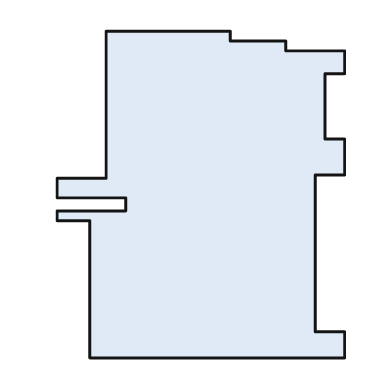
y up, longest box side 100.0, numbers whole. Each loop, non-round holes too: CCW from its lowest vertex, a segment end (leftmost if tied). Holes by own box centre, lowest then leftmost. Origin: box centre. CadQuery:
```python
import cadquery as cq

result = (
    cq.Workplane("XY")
    .moveTo(-34.0, -50.0)
    .lineTo(44.0, -50.0)
    .lineTo(44.0, -42.0)
    .lineTo(35.0, -42.0)
    .lineTo(35.0, 6.0)
    .lineTo(44.0, 6.0)
    .lineTo(44.0, 17.0)
    .lineTo(38.0, 17.0)
    .lineTo(38.0, 37.0)
    .lineTo(44.0, 37.0)
    .lineTo(44.0, 44.0)
    .lineTo(26.0, 44.0)
    .lineTo(26.0, 47.0)
    .lineTo(9.0, 47.0)
    .lineTo(9.0, 50.0)
    .lineTo(-29.0, 50.0)
    .lineTo(-29.0, 5.0)
    .lineTo(-44.0, 5.0)
    .lineTo(-44.0, -1.0)
    .lineTo(-23.0, -1.0)
    .lineTo(-23.0, -5.0)
    .lineTo(-44.0, -5.0)
    .lineTo(-44.0, -8.0)
    .lineTo(-34.0, -8.0)
    .close()
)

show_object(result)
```